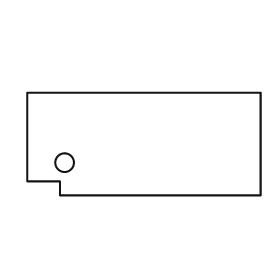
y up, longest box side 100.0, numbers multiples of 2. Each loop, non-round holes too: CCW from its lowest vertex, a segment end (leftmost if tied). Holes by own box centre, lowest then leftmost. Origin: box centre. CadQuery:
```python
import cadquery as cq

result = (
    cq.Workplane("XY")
    .moveTo(-36.0, -22.0)
    .lineTo(50.0, -22.0)
    .lineTo(50.0, 22.0)
    .lineTo(-50.0, 22.0)
    .lineTo(-50.0, -16.0)
    .lineTo(-36.0, -16.0)
    .close()
    .moveTo(-34.0, -8.0)
    .circle(4.0)
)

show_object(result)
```